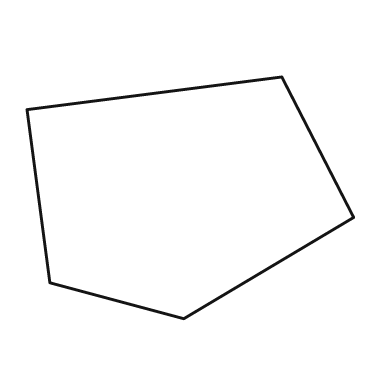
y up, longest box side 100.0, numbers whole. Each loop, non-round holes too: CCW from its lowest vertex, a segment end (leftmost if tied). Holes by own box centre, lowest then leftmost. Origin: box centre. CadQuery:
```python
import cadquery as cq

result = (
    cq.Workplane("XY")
    .moveTo(-2.0, -37.0)
    .lineTo(50.0, -6.0)
    .lineTo(28.0, 37.0)
    .lineTo(-50.0, 27.0)
    .lineTo(-43.0, -26.0)
    .close()
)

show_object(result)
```